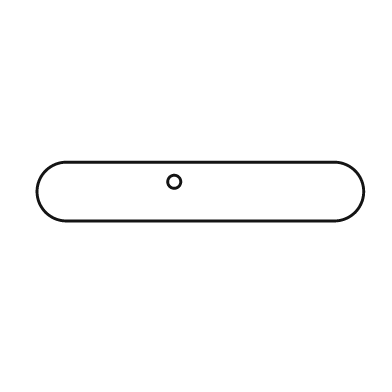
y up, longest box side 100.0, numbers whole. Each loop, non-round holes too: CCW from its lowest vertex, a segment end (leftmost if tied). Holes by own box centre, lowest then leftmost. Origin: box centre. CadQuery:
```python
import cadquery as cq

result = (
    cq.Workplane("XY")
    .moveTo(-41.0, -9.0)
    .lineTo(41.0, -9.0)
    .threePointArc((50.0, 0.0), (41.0, 9.0))
    .lineTo(-41.0, 9.0)
    .threePointArc((-50.0, 0.0), (-41.0, -9.0))
    .close()
    .moveTo(-8.0, 3.0)
    .circle(2.0)
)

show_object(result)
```